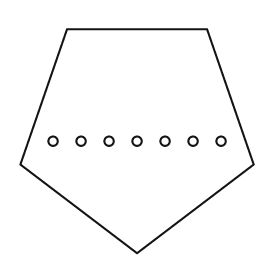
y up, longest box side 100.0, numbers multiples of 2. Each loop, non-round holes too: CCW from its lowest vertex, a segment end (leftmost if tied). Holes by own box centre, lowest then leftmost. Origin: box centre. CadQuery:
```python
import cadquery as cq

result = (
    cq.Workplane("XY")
    .moveTo(0.0, -48.0)
    .lineTo(50.0, -10.0)
    .lineTo(30.0, 48.0)
    .lineTo(-30.0, 48.0)
    .lineTo(-50.0, -10.0)
    .close()
    .moveTo(-36.0, 0.0)
    .circle(2.0)
    .moveTo(-24.0, 0.0)
    .circle(2.0)
    .moveTo(-12.0, 0.0)
    .circle(2.0)
    .moveTo(0.0, 0.0)
    .circle(2.0)
    .moveTo(12.0, 0.0)
    .circle(2.0)
    .moveTo(24.0, 0.0)
    .circle(2.0)
    .moveTo(36.0, 0.0)
    .circle(2.0)
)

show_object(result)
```